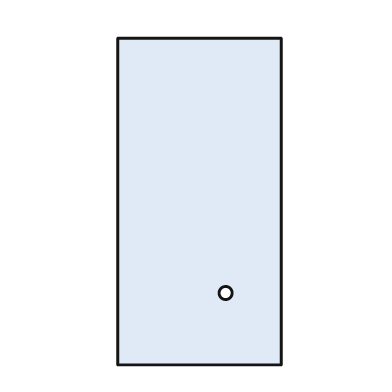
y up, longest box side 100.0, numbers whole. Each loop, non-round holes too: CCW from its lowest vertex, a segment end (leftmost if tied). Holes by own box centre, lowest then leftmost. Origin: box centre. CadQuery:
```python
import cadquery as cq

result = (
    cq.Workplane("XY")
    .moveTo(-25.0, -50.0)
    .lineTo(25.0, -50.0)
    .lineTo(25.0, 50.0)
    .lineTo(-25.0, 50.0)
    .close()
    .moveTo(8.0, -28.0)
    .circle(2.0)
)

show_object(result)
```